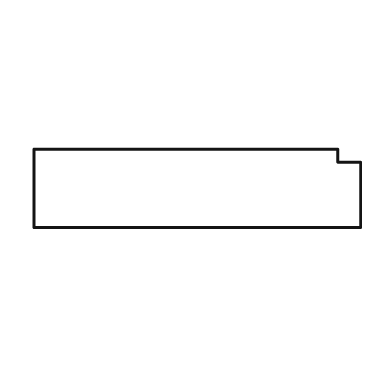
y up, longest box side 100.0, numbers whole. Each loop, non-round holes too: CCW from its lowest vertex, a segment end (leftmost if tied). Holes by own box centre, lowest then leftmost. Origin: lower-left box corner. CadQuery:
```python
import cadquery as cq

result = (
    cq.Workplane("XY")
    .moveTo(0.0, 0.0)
    .lineTo(100.0, 0.0)
    .lineTo(100.0, 20.0)
    .lineTo(93.0, 20.0)
    .lineTo(93.0, 24.0)
    .lineTo(0.0, 24.0)
    .close()
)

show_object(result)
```